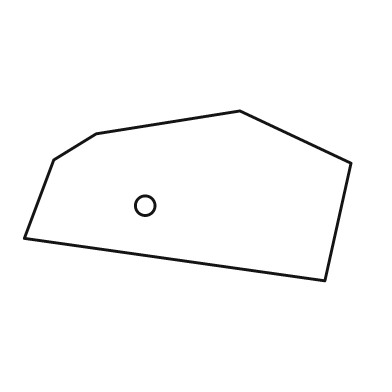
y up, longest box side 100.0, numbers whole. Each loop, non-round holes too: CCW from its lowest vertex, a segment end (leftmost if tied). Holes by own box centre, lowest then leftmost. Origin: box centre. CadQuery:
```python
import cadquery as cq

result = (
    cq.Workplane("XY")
    .moveTo(42.0, -26.0)
    .lineTo(50.0, 10.0)
    .lineTo(16.0, 26.0)
    .lineTo(-28.0, 19.0)
    .lineTo(-41.0, 11.0)
    .lineTo(-50.0, -13.0)
    .close()
    .moveTo(-13.0, -3.0)
    .circle(3.0)
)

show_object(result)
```